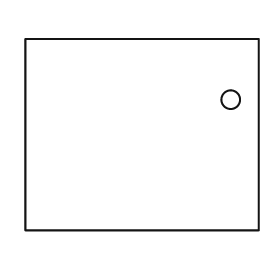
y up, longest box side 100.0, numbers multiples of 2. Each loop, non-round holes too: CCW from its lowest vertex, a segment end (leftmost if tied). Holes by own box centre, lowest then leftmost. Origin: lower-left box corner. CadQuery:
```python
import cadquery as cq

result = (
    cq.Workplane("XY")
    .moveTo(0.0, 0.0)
    .lineTo(100.0, 0.0)
    .lineTo(100.0, 82.0)
    .lineTo(0.0, 82.0)
    .close()
    .moveTo(88.0, 56.0)
    .circle(4.0)
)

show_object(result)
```